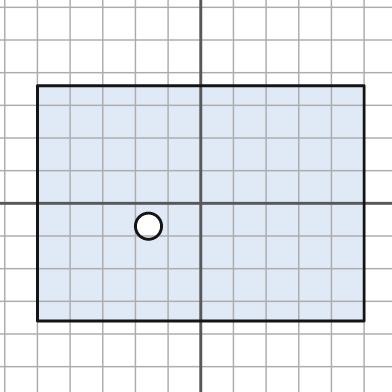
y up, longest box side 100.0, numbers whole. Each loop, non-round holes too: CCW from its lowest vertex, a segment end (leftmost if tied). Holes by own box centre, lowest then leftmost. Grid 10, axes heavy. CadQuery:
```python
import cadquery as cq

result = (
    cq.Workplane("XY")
    .moveTo(-50.0, -36.0)
    .lineTo(50.0, -36.0)
    .lineTo(50.0, 36.0)
    .lineTo(-50.0, 36.0)
    .close()
    .moveTo(-16.0, -7.0)
    .circle(4.0)
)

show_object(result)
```